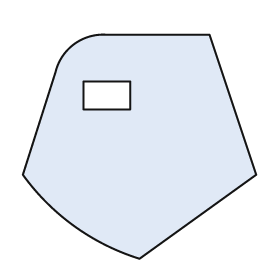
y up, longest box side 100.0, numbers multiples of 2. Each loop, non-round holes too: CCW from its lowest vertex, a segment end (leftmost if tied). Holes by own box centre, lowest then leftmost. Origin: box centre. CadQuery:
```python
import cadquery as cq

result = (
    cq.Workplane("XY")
    .moveTo(0.0, -48.0)
    .lineTo(50.0, -12.0)
    .lineTo(30.0, 48.0)
    .lineTo(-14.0, 48.0)
    .threePointArc((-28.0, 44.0), (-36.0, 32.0))
    .lineTo(-50.0, -12.0)
    .threePointArc((-28.0, -34.0), (0.0, -48.0))
    .close()
    .moveTo(-24.0, 16.0)
    .lineTo(-4.0, 16.0)
    .lineTo(-4.0, 28.0)
    .lineTo(-24.0, 28.0)
    .close()
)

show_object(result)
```